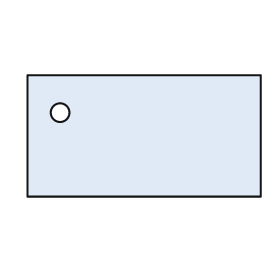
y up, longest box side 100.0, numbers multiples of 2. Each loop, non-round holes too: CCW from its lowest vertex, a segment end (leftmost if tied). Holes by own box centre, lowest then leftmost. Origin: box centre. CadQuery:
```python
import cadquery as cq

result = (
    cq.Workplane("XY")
    .moveTo(-50.0, -26.0)
    .lineTo(50.0, -26.0)
    .lineTo(50.0, 26.0)
    .lineTo(-50.0, 26.0)
    .close()
    .moveTo(-36.0, 10.0)
    .circle(4.0)
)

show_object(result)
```